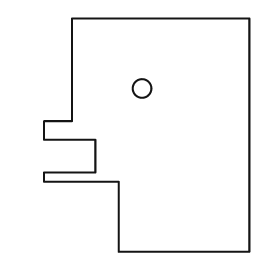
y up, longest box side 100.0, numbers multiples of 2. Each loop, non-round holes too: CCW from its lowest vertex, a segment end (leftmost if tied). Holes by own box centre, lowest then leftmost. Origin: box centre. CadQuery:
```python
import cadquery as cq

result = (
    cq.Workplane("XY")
    .moveTo(-12.0, -50.0)
    .lineTo(44.0, -50.0)
    .lineTo(44.0, 50.0)
    .lineTo(-32.0, 50.0)
    .lineTo(-32.0, 6.0)
    .lineTo(-44.0, 6.0)
    .lineTo(-44.0, -2.0)
    .lineTo(-22.0, -2.0)
    .lineTo(-22.0, -16.0)
    .lineTo(-44.0, -16.0)
    .lineTo(-44.0, -20.0)
    .lineTo(-12.0, -20.0)
    .close()
    .moveTo(-2.0, 20.0)
    .circle(4.0)
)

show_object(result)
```